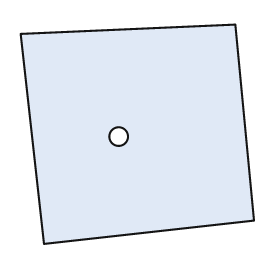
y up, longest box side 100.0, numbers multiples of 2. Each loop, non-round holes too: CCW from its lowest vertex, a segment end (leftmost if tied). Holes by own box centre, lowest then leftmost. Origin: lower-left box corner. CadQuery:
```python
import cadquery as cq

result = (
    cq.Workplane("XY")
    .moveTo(10.0, 0.0)
    .lineTo(100.0, 10.0)
    .lineTo(92.0, 94.0)
    .lineTo(0.0, 90.0)
    .close()
    .moveTo(42.0, 46.0)
    .circle(4.0)
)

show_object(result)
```